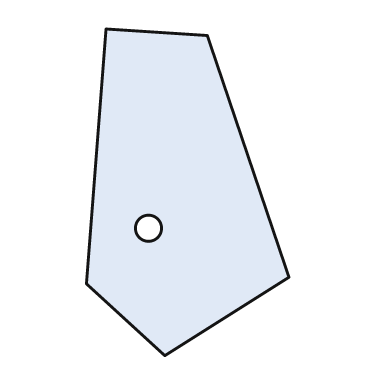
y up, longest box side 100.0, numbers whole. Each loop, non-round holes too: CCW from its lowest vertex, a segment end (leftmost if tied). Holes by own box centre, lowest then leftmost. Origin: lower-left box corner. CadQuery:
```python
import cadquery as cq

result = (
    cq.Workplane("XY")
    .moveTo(24.0, 0.0)
    .lineTo(62.0, 24.0)
    .lineTo(37.0, 98.0)
    .lineTo(6.0, 100.0)
    .lineTo(0.0, 22.0)
    .close()
    .moveTo(19.0, 39.0)
    .circle(4.0)
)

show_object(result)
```